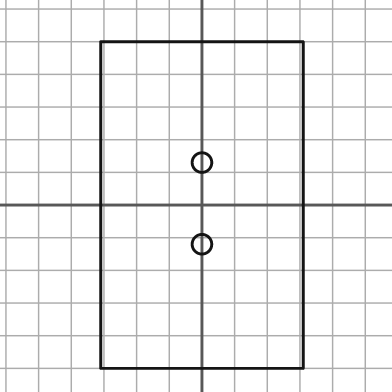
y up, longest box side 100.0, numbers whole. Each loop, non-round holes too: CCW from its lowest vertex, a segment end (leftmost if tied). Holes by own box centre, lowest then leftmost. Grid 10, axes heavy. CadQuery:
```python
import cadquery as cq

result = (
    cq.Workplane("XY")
    .moveTo(-31.0, -50.0)
    .lineTo(31.0, -50.0)
    .lineTo(31.0, 50.0)
    .lineTo(-31.0, 50.0)
    .close()
    .moveTo(0.0, -12.0)
    .circle(3.0)
    .moveTo(0.0, 13.0)
    .circle(3.0)
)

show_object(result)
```